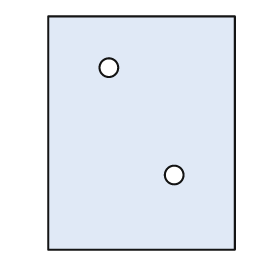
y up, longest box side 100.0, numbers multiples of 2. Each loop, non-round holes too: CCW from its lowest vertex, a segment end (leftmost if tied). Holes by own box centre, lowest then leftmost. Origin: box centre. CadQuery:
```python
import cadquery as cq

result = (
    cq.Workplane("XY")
    .moveTo(-40.0, -50.0)
    .lineTo(40.0, -50.0)
    .lineTo(40.0, 50.0)
    .lineTo(-40.0, 50.0)
    .close()
    .moveTo(14.0, -18.0)
    .circle(4.0)
    .moveTo(-14.0, 28.0)
    .circle(4.0)
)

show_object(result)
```